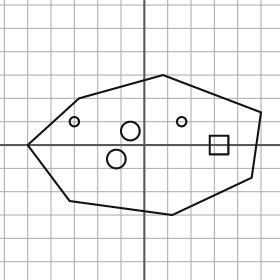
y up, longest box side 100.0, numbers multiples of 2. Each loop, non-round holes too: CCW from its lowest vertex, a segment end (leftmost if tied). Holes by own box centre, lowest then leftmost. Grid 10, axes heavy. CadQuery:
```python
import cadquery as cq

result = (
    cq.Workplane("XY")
    .moveTo(12.0, -30.0)
    .lineTo(46.0, -14.0)
    .lineTo(50.0, 14.0)
    .lineTo(8.0, 30.0)
    .lineTo(-28.0, 20.0)
    .lineTo(-50.0, 0.0)
    .lineTo(-32.0, -24.0)
    .close()
    .moveTo(-12.0, -6.0)
    .circle(4.0)
    .moveTo(28.0, -4.0)
    .lineTo(36.0, -4.0)
    .lineTo(36.0, 4.0)
    .lineTo(28.0, 4.0)
    .close()
    .moveTo(-6.0, 6.0)
    .circle(4.0)
    .moveTo(-30.0, 10.0)
    .circle(2.0)
    .moveTo(16.0, 10.0)
    .circle(2.0)
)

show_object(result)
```